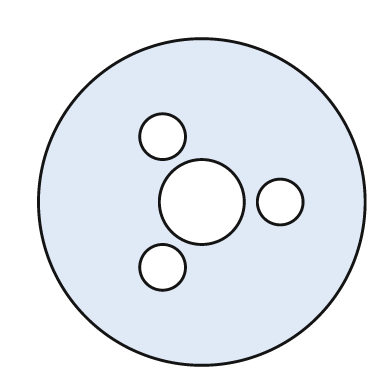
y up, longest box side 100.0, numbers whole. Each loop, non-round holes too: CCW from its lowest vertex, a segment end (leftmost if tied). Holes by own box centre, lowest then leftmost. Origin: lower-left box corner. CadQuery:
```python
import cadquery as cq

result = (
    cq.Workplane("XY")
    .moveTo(50.0, 50.0)
    .circle(50.0)
    .moveTo(38.0, 30.0)
    .circle(7.0)
    .moveTo(50.0, 50.0)
    .circle(13.0)
    .moveTo(74.0, 50.0)
    .circle(7.0)
    .moveTo(38.0, 70.0)
    .circle(7.0)
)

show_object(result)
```